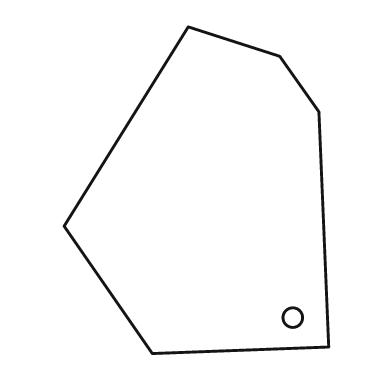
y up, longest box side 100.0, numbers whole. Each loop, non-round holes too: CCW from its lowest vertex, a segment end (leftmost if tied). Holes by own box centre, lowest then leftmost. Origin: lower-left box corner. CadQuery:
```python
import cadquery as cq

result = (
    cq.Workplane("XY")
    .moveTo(27.0, 0.0)
    .lineTo(81.0, 2.0)
    .lineTo(78.0, 74.0)
    .lineTo(66.0, 91.0)
    .lineTo(38.0, 100.0)
    .lineTo(0.0, 39.0)
    .close()
    .moveTo(70.0, 11.0)
    .circle(3.0)
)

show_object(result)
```